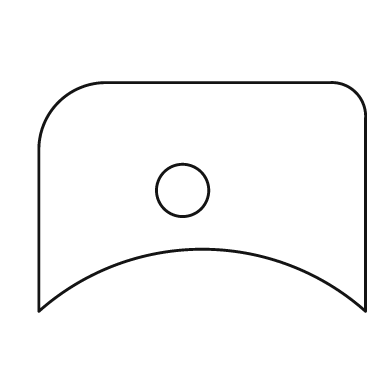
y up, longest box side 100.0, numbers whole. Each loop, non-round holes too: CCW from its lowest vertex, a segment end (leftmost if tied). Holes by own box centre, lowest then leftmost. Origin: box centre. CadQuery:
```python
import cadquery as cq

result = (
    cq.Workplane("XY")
    .moveTo(-50.0, -35.0)
    .threePointArc((0.0, -16.0), (50.0, -35.0))
    .lineTo(50.0, 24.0)
    .threePointArc((47.0, 32.0), (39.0, 35.0))
    .lineTo(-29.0, 35.0)
    .threePointArc((-44.0, 29.0), (-50.0, 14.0))
    .close()
    .moveTo(-6.0, 2.0)
    .circle(8.0)
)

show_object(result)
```